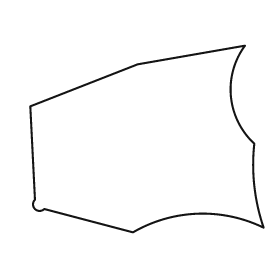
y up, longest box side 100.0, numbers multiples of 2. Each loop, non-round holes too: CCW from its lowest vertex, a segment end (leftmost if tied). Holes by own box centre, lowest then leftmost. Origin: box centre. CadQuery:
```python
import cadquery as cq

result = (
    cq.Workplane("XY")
    .moveTo(-6.0, -40.0)
    .threePointArc((22.0, -32.0), (50.0, -38.0))
    .threePointArc((46.0, -20.0), (46.0, -2.0))
    .threePointArc((36.0, 18.0), (42.0, 40.0))
    .lineTo(-4.0, 32.0)
    .lineTo(-50.0, 14.0)
    .lineTo(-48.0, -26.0)
    .threePointArc((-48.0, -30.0), (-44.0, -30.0))
    .close()
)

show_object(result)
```